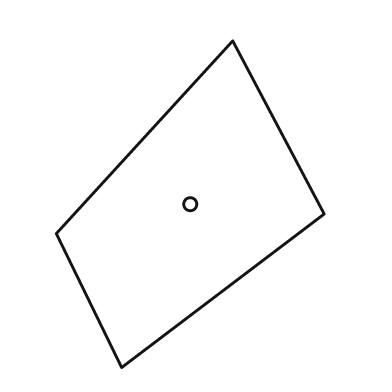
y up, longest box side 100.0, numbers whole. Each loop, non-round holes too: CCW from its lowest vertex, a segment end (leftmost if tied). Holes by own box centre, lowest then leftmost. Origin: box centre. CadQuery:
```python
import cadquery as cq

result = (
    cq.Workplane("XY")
    .moveTo(-21.0, -50.0)
    .lineTo(41.0, -3.0)
    .lineTo(13.0, 50.0)
    .lineTo(-41.0, -9.0)
    .close()
    .moveTo(0.0, 0.0)
    .circle(2.0)
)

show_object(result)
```